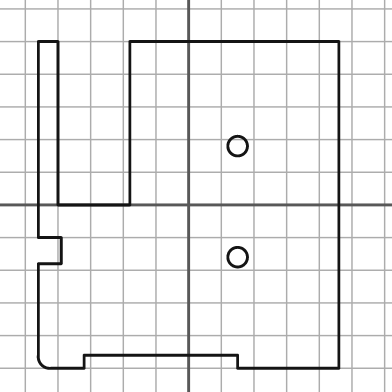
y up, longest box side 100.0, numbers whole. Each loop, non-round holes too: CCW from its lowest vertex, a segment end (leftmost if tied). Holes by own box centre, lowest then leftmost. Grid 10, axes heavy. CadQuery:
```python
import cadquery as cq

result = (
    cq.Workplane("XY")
    .moveTo(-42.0, -50.0)
    .lineTo(-32.0, -50.0)
    .lineTo(-32.0, -46.0)
    .lineTo(15.0, -46.0)
    .lineTo(15.0, -50.0)
    .lineTo(46.0, -50.0)
    .lineTo(46.0, 50.0)
    .lineTo(-18.0, 50.0)
    .lineTo(-18.0, 0.0)
    .lineTo(-40.0, 0.0)
    .lineTo(-40.0, 50.0)
    .lineTo(-46.0, 50.0)
    .lineTo(-46.0, -10.0)
    .lineTo(-39.0, -10.0)
    .lineTo(-39.0, -18.0)
    .lineTo(-46.0, -18.0)
    .lineTo(-46.0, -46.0)
    .threePointArc((-45.0, -49.0), (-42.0, -50.0))
    .close()
    .moveTo(15.0, -16.0)
    .circle(3.0)
    .moveTo(15.0, 18.0)
    .circle(3.0)
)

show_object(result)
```